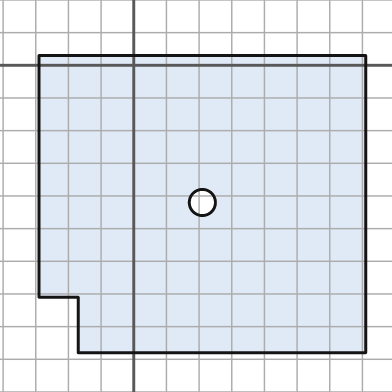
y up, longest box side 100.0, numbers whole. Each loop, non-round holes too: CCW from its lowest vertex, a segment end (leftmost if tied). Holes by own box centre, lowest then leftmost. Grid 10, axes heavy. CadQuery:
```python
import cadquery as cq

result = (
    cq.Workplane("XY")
    .moveTo(-17.0, -88.0)
    .lineTo(71.0, -88.0)
    .lineTo(71.0, 3.0)
    .lineTo(-29.0, 3.0)
    .lineTo(-29.0, -71.0)
    .lineTo(-17.0, -71.0)
    .close()
    .moveTo(21.0, -42.0)
    .circle(4.0)
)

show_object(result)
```